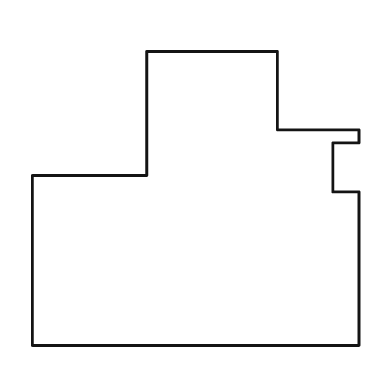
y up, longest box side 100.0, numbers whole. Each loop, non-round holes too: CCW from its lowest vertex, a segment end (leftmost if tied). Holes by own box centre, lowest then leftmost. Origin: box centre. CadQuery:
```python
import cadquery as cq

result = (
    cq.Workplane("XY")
    .moveTo(-50.0, -45.0)
    .lineTo(50.0, -45.0)
    .lineTo(50.0, 2.0)
    .lineTo(42.0, 2.0)
    .lineTo(42.0, 17.0)
    .lineTo(50.0, 17.0)
    .lineTo(50.0, 21.0)
    .lineTo(25.0, 21.0)
    .lineTo(25.0, 45.0)
    .lineTo(-15.0, 45.0)
    .lineTo(-15.0, 7.0)
    .lineTo(-50.0, 7.0)
    .close()
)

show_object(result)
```